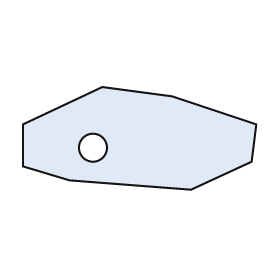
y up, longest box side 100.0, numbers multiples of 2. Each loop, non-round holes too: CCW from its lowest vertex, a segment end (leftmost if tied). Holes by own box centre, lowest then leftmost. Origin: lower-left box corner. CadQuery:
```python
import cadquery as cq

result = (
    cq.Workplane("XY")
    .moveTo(72.0, 0.0)
    .lineTo(98.0, 12.0)
    .lineTo(100.0, 28.0)
    .lineTo(64.0, 40.0)
    .lineTo(34.0, 44.0)
    .lineTo(0.0, 28.0)
    .lineTo(0.0, 10.0)
    .lineTo(20.0, 4.0)
    .close()
    .moveTo(30.0, 18.0)
    .circle(6.0)
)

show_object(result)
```